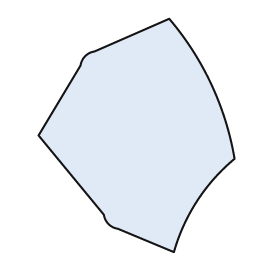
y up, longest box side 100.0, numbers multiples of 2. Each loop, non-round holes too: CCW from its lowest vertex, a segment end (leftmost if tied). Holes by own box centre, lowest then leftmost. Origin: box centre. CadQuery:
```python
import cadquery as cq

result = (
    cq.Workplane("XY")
    .moveTo(16.0, -50.0)
    .threePointArc((26.0, -28.0), (42.0, -10.0))
    .threePointArc((32.0, 22.0), (14.0, 50.0))
    .lineTo(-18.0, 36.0)
    .threePointArc((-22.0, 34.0), (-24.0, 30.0))
    .lineTo(-42.0, 0.0)
    .lineTo(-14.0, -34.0)
    .threePointArc((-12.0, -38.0), (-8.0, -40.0))
    .close()
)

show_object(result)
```